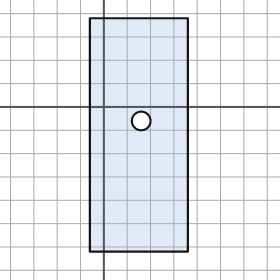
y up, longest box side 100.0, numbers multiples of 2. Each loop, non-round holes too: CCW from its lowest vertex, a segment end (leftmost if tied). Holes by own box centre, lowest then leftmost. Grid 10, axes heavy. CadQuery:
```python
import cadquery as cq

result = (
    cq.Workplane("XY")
    .moveTo(-6.0, -62.0)
    .lineTo(36.0, -62.0)
    .lineTo(36.0, 38.0)
    .lineTo(-6.0, 38.0)
    .close()
    .moveTo(16.0, -6.0)
    .circle(4.0)
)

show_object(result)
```